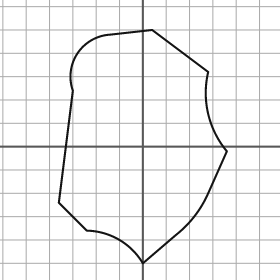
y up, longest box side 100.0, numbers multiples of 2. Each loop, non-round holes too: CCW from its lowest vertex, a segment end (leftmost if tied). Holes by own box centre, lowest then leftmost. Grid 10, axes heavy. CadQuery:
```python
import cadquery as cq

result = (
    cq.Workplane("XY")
    .moveTo(0.0, -50.0)
    .lineTo(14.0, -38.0)
    .threePointArc((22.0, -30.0), (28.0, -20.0))
    .lineTo(36.0, -2.0)
    .threePointArc((28.0, 14.0), (28.0, 32.0))
    .lineTo(4.0, 50.0)
    .lineTo(-14.0, 48.0)
    .threePointArc((-28.0, 40.0), (-30.0, 24.0))
    .lineTo(-36.0, -24.0)
    .lineTo(-24.0, -36.0)
    .threePointArc((-10.0, -40.0), (0.0, -50.0))
    .close()
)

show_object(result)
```